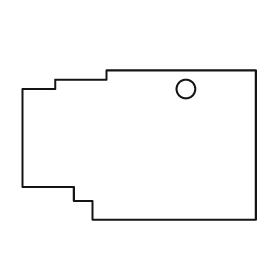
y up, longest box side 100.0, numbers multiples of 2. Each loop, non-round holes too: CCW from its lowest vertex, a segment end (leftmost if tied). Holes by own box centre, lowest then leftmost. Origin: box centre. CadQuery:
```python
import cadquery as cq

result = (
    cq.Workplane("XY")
    .moveTo(-20.0, -32.0)
    .lineTo(50.0, -32.0)
    .lineTo(50.0, 32.0)
    .lineTo(-14.0, 32.0)
    .lineTo(-14.0, 28.0)
    .lineTo(-36.0, 28.0)
    .lineTo(-36.0, 24.0)
    .lineTo(-50.0, 24.0)
    .lineTo(-50.0, -18.0)
    .lineTo(-28.0, -18.0)
    .lineTo(-28.0, -24.0)
    .lineTo(-20.0, -24.0)
    .close()
    .moveTo(20.0, 24.0)
    .circle(4.0)
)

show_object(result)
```